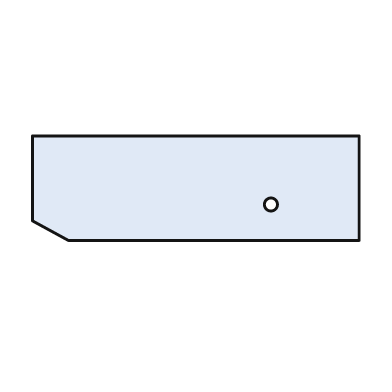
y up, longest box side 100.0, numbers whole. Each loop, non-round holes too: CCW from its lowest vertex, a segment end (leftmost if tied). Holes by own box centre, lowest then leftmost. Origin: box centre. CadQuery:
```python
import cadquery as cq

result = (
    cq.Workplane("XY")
    .moveTo(-39.0, -16.0)
    .lineTo(50.0, -16.0)
    .lineTo(50.0, 16.0)
    .lineTo(-50.0, 16.0)
    .lineTo(-50.0, -10.0)
    .close()
    .moveTo(23.0, -5.0)
    .circle(2.0)
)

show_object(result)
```